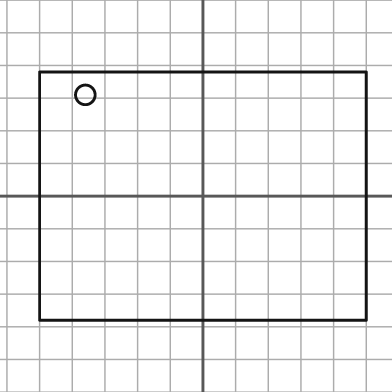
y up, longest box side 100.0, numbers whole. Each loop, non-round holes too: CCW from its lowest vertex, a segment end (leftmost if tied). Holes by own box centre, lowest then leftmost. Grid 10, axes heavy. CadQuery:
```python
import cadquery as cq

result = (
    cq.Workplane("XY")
    .moveTo(-50.0, -38.0)
    .lineTo(50.0, -38.0)
    .lineTo(50.0, 38.0)
    .lineTo(-50.0, 38.0)
    .close()
    .moveTo(-36.0, 31.0)
    .circle(3.0)
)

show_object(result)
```